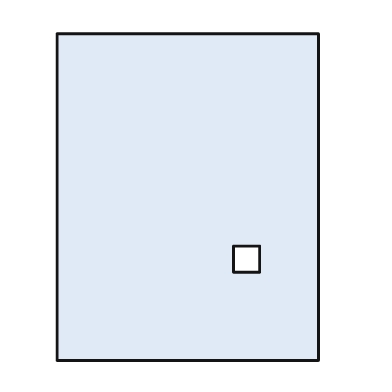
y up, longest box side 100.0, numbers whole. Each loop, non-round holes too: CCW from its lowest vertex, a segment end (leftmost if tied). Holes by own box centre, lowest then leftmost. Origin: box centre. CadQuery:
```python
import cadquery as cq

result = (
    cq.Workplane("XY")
    .moveTo(-40.0, -50.0)
    .lineTo(40.0, -50.0)
    .lineTo(40.0, 50.0)
    .lineTo(-40.0, 50.0)
    .close()
    .moveTo(14.0, -23.0)
    .lineTo(22.0, -23.0)
    .lineTo(22.0, -15.0)
    .lineTo(14.0, -15.0)
    .close()
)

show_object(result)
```